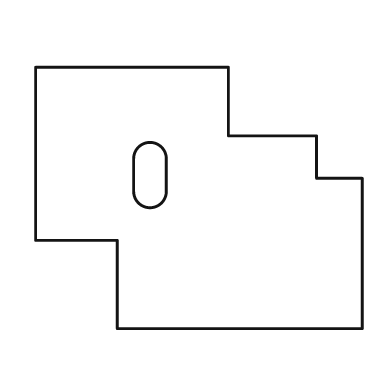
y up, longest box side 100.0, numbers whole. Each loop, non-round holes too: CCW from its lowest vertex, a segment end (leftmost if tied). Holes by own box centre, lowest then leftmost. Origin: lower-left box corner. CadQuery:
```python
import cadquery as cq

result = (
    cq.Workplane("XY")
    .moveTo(25.0, 0.0)
    .lineTo(100.0, 0.0)
    .lineTo(100.0, 46.0)
    .lineTo(86.0, 46.0)
    .lineTo(86.0, 59.0)
    .lineTo(59.0, 59.0)
    .lineTo(59.0, 80.0)
    .lineTo(0.0, 80.0)
    .lineTo(0.0, 27.0)
    .lineTo(25.0, 27.0)
    .close()
    .moveTo(30.0, 42.0)
    .threePointArc((35.0, 37.0), (40.0, 42.0))
    .lineTo(40.0, 52.0)
    .threePointArc((35.0, 57.0), (30.0, 52.0))
    .close()
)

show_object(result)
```